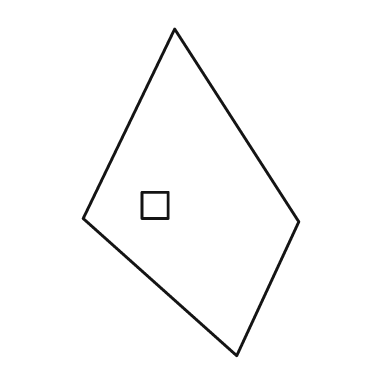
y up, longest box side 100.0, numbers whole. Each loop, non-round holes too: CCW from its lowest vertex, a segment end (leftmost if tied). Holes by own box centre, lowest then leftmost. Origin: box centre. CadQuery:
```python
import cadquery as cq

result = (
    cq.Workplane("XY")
    .moveTo(14.0, -50.0)
    .lineTo(33.0, -9.0)
    .lineTo(-5.0, 50.0)
    .lineTo(-33.0, -8.0)
    .close()
    .moveTo(-15.0, -8.0)
    .lineTo(-7.0, -8.0)
    .lineTo(-7.0, 0.0)
    .lineTo(-15.0, 0.0)
    .close()
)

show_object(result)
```